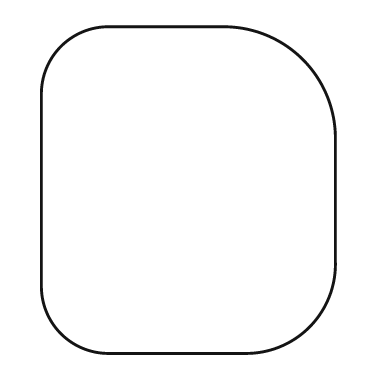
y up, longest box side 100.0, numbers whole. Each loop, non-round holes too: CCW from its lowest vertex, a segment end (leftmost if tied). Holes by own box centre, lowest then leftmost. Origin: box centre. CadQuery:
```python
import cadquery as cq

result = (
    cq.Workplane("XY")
    .moveTo(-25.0, -50.0)
    .lineTo(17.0, -50.0)
    .threePointArc((37.0, -42.0), (45.0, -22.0))
    .lineTo(45.0, 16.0)
    .threePointArc((35.0, 40.0), (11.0, 50.0))
    .lineTo(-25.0, 50.0)
    .threePointArc((-39.0, 44.0), (-45.0, 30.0))
    .lineTo(-45.0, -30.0)
    .threePointArc((-39.0, -44.0), (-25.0, -50.0))
    .close()
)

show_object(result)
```